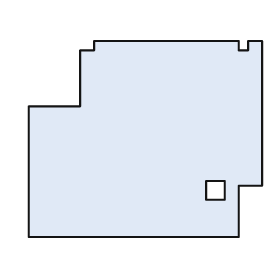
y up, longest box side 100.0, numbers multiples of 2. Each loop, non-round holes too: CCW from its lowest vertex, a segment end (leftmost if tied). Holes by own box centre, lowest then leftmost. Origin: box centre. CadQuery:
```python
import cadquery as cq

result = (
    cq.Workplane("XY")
    .moveTo(-50.0, -42.0)
    .lineTo(40.0, -42.0)
    .lineTo(40.0, -20.0)
    .lineTo(50.0, -20.0)
    .lineTo(50.0, 42.0)
    .lineTo(44.0, 42.0)
    .lineTo(44.0, 38.0)
    .lineTo(40.0, 38.0)
    .lineTo(40.0, 42.0)
    .lineTo(-22.0, 42.0)
    .lineTo(-22.0, 38.0)
    .lineTo(-28.0, 38.0)
    .lineTo(-28.0, 14.0)
    .lineTo(-50.0, 14.0)
    .close()
    .moveTo(26.0, -26.0)
    .lineTo(34.0, -26.0)
    .lineTo(34.0, -18.0)
    .lineTo(26.0, -18.0)
    .close()
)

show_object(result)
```